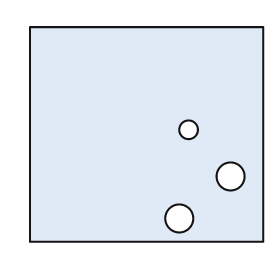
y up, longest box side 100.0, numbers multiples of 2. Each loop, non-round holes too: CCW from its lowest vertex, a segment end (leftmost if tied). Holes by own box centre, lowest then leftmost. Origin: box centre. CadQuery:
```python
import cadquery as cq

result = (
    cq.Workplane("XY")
    .moveTo(-50.0, -46.0)
    .lineTo(50.0, -46.0)
    .lineTo(50.0, 46.0)
    .lineTo(-50.0, 46.0)
    .close()
    .moveTo(14.0, -36.0)
    .circle(6.0)
    .moveTo(36.0, -18.0)
    .circle(6.0)
    .moveTo(18.0, 2.0)
    .circle(4.0)
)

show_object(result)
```